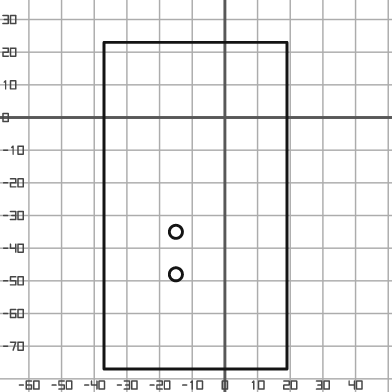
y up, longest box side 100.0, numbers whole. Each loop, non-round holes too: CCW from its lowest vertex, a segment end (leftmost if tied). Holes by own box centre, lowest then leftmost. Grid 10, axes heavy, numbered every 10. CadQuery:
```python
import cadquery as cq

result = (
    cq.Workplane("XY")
    .moveTo(-37.0, -77.0)
    .lineTo(19.0, -77.0)
    .lineTo(19.0, 23.0)
    .lineTo(-37.0, 23.0)
    .close()
    .moveTo(-15.0, -48.0)
    .circle(2.0)
    .moveTo(-15.0, -35.0)
    .circle(2.0)
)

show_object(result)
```